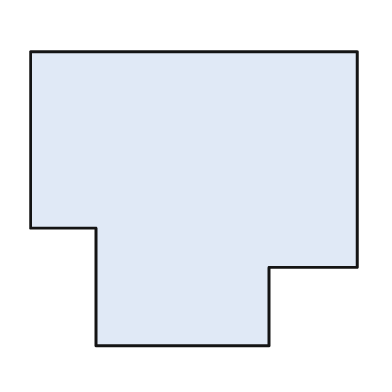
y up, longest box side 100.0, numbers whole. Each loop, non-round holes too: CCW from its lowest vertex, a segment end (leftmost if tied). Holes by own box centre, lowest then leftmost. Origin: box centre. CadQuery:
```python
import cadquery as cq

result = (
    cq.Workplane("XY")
    .moveTo(-30.0, -45.0)
    .lineTo(23.0, -45.0)
    .lineTo(23.0, -21.0)
    .lineTo(50.0, -21.0)
    .lineTo(50.0, 45.0)
    .lineTo(-50.0, 45.0)
    .lineTo(-50.0, -9.0)
    .lineTo(-30.0, -9.0)
    .close()
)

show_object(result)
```